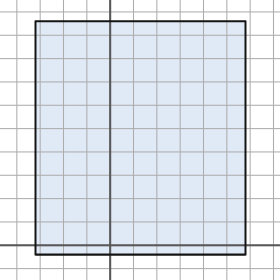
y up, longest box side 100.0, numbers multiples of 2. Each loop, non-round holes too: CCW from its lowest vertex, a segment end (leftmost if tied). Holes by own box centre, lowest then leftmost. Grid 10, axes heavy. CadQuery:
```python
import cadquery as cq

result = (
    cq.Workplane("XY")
    .moveTo(-32.0, -4.0)
    .lineTo(58.0, -4.0)
    .lineTo(58.0, 96.0)
    .lineTo(-32.0, 96.0)
    .close()
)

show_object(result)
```